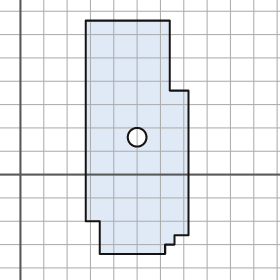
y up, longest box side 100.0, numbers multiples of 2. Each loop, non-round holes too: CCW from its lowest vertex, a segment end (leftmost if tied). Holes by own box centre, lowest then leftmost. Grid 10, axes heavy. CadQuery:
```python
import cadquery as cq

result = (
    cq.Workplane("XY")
    .moveTo(34.0, -34.0)
    .lineTo(62.0, -34.0)
    .lineTo(62.0, -30.0)
    .lineTo(66.0, -30.0)
    .lineTo(66.0, -26.0)
    .lineTo(72.0, -26.0)
    .lineTo(72.0, 36.0)
    .lineTo(64.0, 36.0)
    .lineTo(64.0, 66.0)
    .lineTo(28.0, 66.0)
    .lineTo(28.0, -20.0)
    .lineTo(34.0, -20.0)
    .close()
    .moveTo(50.0, 16.0)
    .circle(4.0)
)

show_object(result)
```